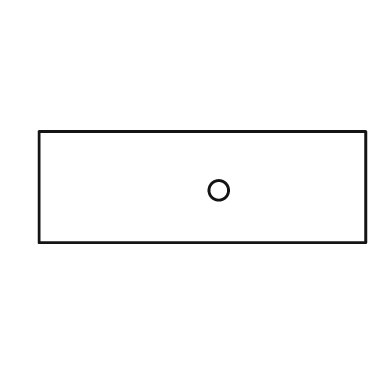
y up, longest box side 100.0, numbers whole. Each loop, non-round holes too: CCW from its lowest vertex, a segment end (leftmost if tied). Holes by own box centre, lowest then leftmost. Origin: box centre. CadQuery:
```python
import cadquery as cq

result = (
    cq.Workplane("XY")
    .moveTo(-50.0, -17.0)
    .lineTo(50.0, -17.0)
    .lineTo(50.0, 17.0)
    .lineTo(-50.0, 17.0)
    .close()
    .moveTo(5.0, -1.0)
    .circle(3.0)
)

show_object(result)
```